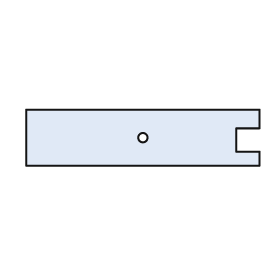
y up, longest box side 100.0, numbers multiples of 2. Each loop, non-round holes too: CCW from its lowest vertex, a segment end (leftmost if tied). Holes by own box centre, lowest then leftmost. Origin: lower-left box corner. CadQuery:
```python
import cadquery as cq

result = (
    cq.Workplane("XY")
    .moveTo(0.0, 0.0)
    .lineTo(100.0, 0.0)
    .lineTo(100.0, 6.0)
    .lineTo(90.0, 6.0)
    .lineTo(90.0, 16.0)
    .lineTo(100.0, 16.0)
    .lineTo(100.0, 24.0)
    .lineTo(0.0, 24.0)
    .close()
    .moveTo(50.0, 12.0)
    .circle(2.0)
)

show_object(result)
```